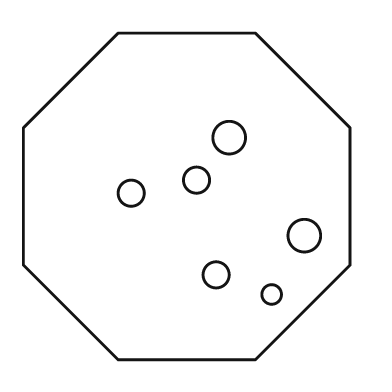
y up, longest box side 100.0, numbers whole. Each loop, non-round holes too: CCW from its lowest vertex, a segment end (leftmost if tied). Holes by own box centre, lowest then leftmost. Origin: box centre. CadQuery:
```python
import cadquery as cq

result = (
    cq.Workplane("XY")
    .moveTo(-21.0, -50.0)
    .lineTo(21.0, -50.0)
    .lineTo(50.0, -21.0)
    .lineTo(50.0, 21.0)
    .lineTo(21.0, 50.0)
    .lineTo(-21.0, 50.0)
    .lineTo(-50.0, 21.0)
    .lineTo(-50.0, -21.0)
    .close()
    .moveTo(26.0, -30.0)
    .circle(3.0)
    .moveTo(9.0, -24.0)
    .circle(4.0)
    .moveTo(36.0, -12.0)
    .circle(5.0)
    .moveTo(-17.0, 1.0)
    .circle(4.0)
    .moveTo(3.0, 5.0)
    .circle(4.0)
    .moveTo(13.0, 18.0)
    .circle(5.0)
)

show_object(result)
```